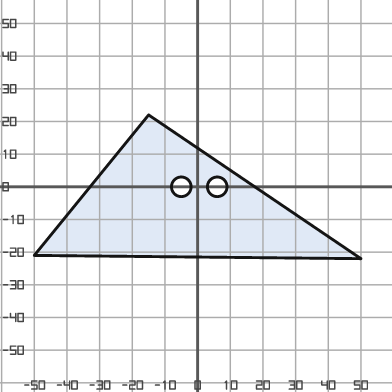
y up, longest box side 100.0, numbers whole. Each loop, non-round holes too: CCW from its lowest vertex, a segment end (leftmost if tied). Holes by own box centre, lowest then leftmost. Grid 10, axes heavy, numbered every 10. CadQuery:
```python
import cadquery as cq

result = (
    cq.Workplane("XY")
    .moveTo(50.0, -22.0)
    .lineTo(-15.0, 22.0)
    .lineTo(-50.0, -21.0)
    .close()
    .moveTo(-5.0, 0.0)
    .circle(3.0)
    .moveTo(6.0, 0.0)
    .circle(3.0)
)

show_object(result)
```